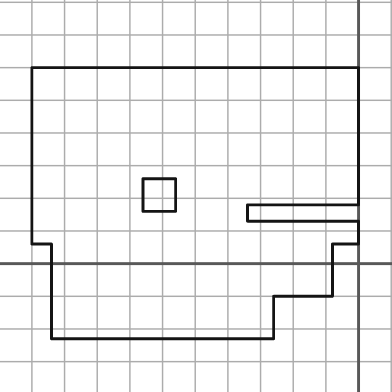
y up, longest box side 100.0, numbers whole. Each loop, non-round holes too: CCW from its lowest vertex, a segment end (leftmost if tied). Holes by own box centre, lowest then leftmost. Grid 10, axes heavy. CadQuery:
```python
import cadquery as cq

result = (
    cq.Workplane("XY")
    .moveTo(-94.0, -23.0)
    .lineTo(-26.0, -23.0)
    .lineTo(-26.0, -10.0)
    .lineTo(-8.0, -10.0)
    .lineTo(-8.0, 6.0)
    .lineTo(0.0, 6.0)
    .lineTo(0.0, 13.0)
    .lineTo(-34.0, 13.0)
    .lineTo(-34.0, 18.0)
    .lineTo(0.0, 18.0)
    .lineTo(0.0, 60.0)
    .lineTo(-100.0, 60.0)
    .lineTo(-100.0, 6.0)
    .lineTo(-94.0, 6.0)
    .close()
    .moveTo(-66.0, 16.0)
    .lineTo(-56.0, 16.0)
    .lineTo(-56.0, 26.0)
    .lineTo(-66.0, 26.0)
    .close()
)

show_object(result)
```